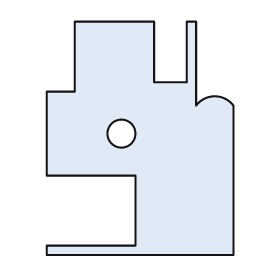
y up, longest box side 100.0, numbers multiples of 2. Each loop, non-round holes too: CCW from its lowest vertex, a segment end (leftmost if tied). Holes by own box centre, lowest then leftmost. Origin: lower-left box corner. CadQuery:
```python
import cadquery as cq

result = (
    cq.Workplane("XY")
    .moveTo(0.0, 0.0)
    .lineTo(80.0, 0.0)
    .lineTo(80.0, 64.0)
    .threePointArc((72.0, 68.0), (64.0, 64.0))
    .lineTo(64.0, 100.0)
    .lineTo(60.0, 100.0)
    .lineTo(60.0, 74.0)
    .lineTo(46.0, 74.0)
    .lineTo(46.0, 100.0)
    .lineTo(12.0, 100.0)
    .lineTo(12.0, 70.0)
    .lineTo(0.0, 70.0)
    .lineTo(0.0, 34.0)
    .lineTo(38.0, 34.0)
    .lineTo(38.0, 4.0)
    .lineTo(0.0, 4.0)
    .close()
    .moveTo(32.0, 52.0)
    .circle(6.0)
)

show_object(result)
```